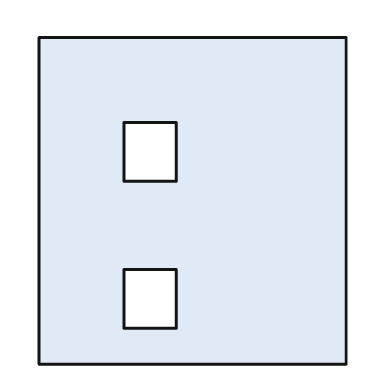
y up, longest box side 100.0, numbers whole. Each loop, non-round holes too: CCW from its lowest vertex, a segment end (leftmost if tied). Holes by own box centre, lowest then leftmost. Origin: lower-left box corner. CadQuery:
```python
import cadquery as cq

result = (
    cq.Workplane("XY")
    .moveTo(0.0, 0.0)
    .lineTo(94.0, 0.0)
    .lineTo(94.0, 100.0)
    .lineTo(0.0, 100.0)
    .close()
    .moveTo(26.0, 11.0)
    .lineTo(42.0, 11.0)
    .lineTo(42.0, 29.0)
    .lineTo(26.0, 29.0)
    .close()
    .moveTo(26.0, 56.0)
    .lineTo(42.0, 56.0)
    .lineTo(42.0, 74.0)
    .lineTo(26.0, 74.0)
    .close()
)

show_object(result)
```